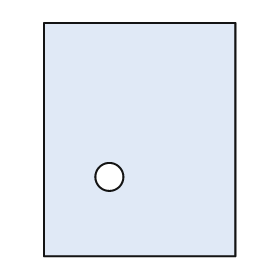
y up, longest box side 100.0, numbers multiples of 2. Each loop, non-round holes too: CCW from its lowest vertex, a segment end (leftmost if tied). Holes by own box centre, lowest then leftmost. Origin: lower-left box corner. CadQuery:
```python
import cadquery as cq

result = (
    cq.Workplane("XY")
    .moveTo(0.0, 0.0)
    .lineTo(82.0, 0.0)
    .lineTo(82.0, 100.0)
    .lineTo(0.0, 100.0)
    .close()
    .moveTo(28.0, 34.0)
    .circle(6.0)
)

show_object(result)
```